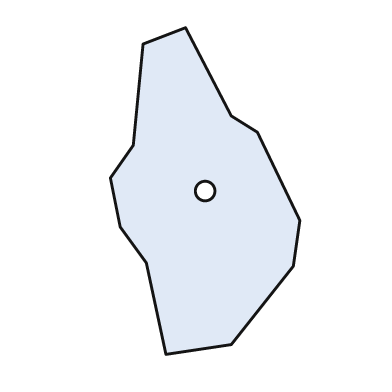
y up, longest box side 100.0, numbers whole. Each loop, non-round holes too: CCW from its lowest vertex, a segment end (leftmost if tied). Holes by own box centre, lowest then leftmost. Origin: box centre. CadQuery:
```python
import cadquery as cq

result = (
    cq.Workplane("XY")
    .moveTo(-12.0, -50.0)
    .lineTo(8.0, -47.0)
    .lineTo(27.0, -23.0)
    .lineTo(29.0, -9.0)
    .lineTo(16.0, 18.0)
    .lineTo(8.0, 23.0)
    .lineTo(-6.0, 50.0)
    .lineTo(-19.0, 45.0)
    .lineTo(-22.0, 14.0)
    .lineTo(-29.0, 4.0)
    .lineTo(-26.0, -11.0)
    .lineTo(-18.0, -22.0)
    .close()
    .moveTo(0.0, 0.0)
    .circle(3.0)
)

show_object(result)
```